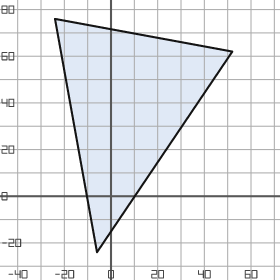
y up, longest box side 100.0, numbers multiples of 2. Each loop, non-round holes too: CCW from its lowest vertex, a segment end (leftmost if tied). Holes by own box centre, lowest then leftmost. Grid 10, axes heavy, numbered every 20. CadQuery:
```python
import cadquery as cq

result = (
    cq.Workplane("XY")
    .moveTo(-6.0, -24.0)
    .lineTo(52.0, 62.0)
    .lineTo(-24.0, 76.0)
    .close()
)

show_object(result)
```